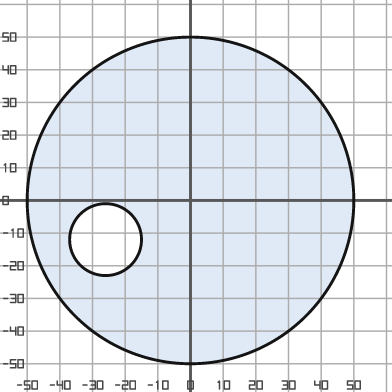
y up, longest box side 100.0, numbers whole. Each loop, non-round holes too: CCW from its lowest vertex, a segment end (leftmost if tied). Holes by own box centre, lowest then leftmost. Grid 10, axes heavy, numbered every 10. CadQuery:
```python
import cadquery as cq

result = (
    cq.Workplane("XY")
    .moveTo(0.0, 0.0)
    .circle(50.0)
    .moveTo(-26.0, -12.0)
    .circle(11.0)
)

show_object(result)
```